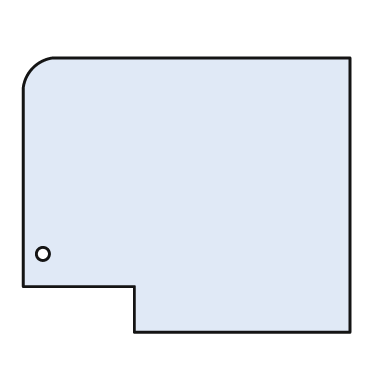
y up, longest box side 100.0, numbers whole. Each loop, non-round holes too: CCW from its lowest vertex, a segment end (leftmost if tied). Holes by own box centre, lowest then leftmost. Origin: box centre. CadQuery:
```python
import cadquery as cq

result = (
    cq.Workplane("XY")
    .moveTo(-16.0, -42.0)
    .lineTo(50.0, -42.0)
    .lineTo(50.0, 42.0)
    .lineTo(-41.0, 42.0)
    .threePointArc((-47.0, 39.0), (-50.0, 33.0))
    .lineTo(-50.0, -28.0)
    .lineTo(-16.0, -28.0)
    .close()
    .moveTo(-44.0, -18.0)
    .circle(2.0)
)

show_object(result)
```